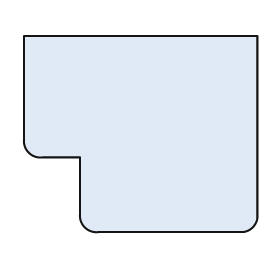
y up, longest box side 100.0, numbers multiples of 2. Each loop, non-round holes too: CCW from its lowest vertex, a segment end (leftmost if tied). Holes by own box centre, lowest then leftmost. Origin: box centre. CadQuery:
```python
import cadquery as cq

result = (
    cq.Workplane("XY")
    .moveTo(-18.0, -42.0)
    .lineTo(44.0, -42.0)
    .threePointArc((48.0, -40.0), (50.0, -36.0))
    .lineTo(50.0, 42.0)
    .lineTo(-50.0, 42.0)
    .lineTo(-50.0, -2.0)
    .threePointArc((-48.0, -8.0), (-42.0, -10.0))
    .lineTo(-26.0, -10.0)
    .lineTo(-26.0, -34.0)
    .threePointArc((-24.0, -40.0), (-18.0, -42.0))
    .close()
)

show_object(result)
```